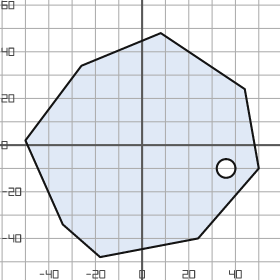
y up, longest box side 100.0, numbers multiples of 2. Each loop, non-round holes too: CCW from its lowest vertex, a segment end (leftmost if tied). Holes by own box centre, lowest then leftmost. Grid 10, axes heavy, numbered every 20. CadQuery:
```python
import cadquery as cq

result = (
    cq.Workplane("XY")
    .moveTo(-18.0, -48.0)
    .lineTo(24.0, -40.0)
    .lineTo(50.0, -10.0)
    .lineTo(44.0, 24.0)
    .lineTo(8.0, 48.0)
    .lineTo(-26.0, 34.0)
    .lineTo(-50.0, 2.0)
    .lineTo(-34.0, -34.0)
    .close()
    .moveTo(36.0, -10.0)
    .circle(4.0)
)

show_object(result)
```